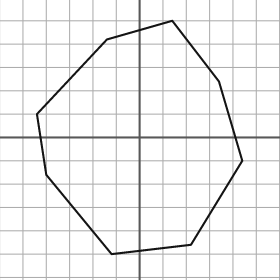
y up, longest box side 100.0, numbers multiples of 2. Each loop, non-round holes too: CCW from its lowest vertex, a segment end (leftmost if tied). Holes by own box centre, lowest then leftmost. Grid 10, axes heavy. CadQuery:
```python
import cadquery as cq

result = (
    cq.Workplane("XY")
    .moveTo(-12.0, -50.0)
    .lineTo(22.0, -46.0)
    .lineTo(44.0, -10.0)
    .lineTo(34.0, 24.0)
    .lineTo(14.0, 50.0)
    .lineTo(-14.0, 42.0)
    .lineTo(-44.0, 10.0)
    .lineTo(-40.0, -16.0)
    .close()
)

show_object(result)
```